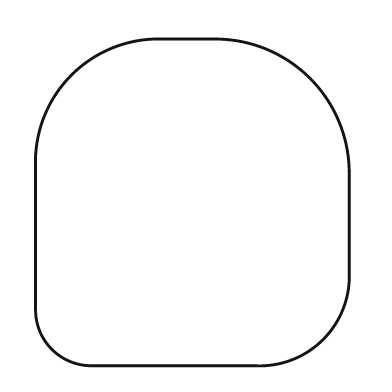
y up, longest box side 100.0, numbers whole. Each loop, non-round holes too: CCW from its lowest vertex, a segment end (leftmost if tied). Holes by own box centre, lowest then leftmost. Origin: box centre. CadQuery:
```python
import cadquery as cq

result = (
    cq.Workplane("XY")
    .moveTo(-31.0, -50.0)
    .lineTo(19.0, -50.0)
    .threePointArc((40.0, -42.0), (48.0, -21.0))
    .lineTo(48.0, 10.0)
    .threePointArc((36.0, 38.0), (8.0, 50.0))
    .lineTo(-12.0, 50.0)
    .threePointArc((-37.0, 39.0), (-48.0, 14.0))
    .lineTo(-48.0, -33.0)
    .threePointArc((-43.0, -45.0), (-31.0, -50.0))
    .close()
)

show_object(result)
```